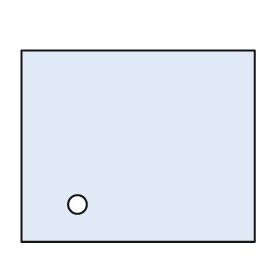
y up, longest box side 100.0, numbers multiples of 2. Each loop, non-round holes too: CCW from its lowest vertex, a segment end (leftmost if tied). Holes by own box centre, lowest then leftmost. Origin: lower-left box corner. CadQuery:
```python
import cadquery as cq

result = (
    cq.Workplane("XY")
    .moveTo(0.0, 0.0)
    .lineTo(100.0, 0.0)
    .lineTo(100.0, 82.0)
    .lineTo(0.0, 82.0)
    .close()
    .moveTo(24.0, 16.0)
    .circle(4.0)
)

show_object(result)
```